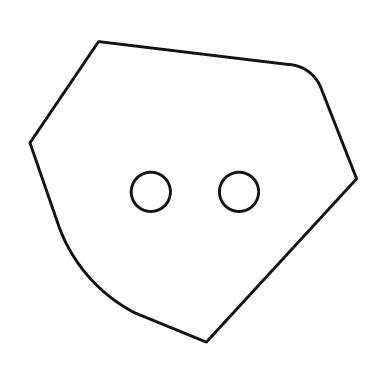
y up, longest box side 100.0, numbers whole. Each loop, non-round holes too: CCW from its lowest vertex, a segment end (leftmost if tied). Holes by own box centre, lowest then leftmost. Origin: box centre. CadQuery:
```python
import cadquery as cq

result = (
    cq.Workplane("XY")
    .moveTo(4.0, -46.0)
    .lineTo(50.0, 4.0)
    .lineTo(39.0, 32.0)
    .threePointArc((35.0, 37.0), (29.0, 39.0))
    .lineTo(-29.0, 46.0)
    .lineTo(-50.0, 15.0)
    .lineTo(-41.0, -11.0)
    .threePointArc((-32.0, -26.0), (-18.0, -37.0))
    .close()
    .moveTo(-13.0, 0.0)
    .circle(6.0)
    .moveTo(14.0, 0.0)
    .circle(6.0)
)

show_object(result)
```